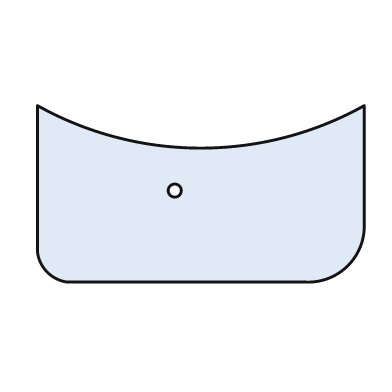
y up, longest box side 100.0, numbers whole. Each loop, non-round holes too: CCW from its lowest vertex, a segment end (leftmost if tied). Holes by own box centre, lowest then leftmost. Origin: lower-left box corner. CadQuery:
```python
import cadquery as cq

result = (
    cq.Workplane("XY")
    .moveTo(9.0, 0.0)
    .lineTo(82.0, 0.0)
    .threePointArc((95.0, 5.0), (100.0, 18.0))
    .lineTo(100.0, 54.0)
    .threePointArc((50.0, 41.0), (0.0, 54.0))
    .lineTo(0.0, 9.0)
    .threePointArc((3.0, 3.0), (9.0, 0.0))
    .close()
    .moveTo(42.0, 28.0)
    .circle(2.0)
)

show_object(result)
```